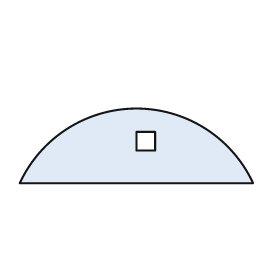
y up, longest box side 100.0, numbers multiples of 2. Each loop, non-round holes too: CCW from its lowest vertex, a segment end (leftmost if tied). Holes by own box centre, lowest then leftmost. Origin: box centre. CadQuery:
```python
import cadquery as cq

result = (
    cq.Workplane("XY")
    .moveTo(-50.0, -16.0)
    .lineTo(50.0, -16.0)
    .threePointArc((0.0, 16.0), (-50.0, -16.0))
    .close()
    .moveTo(0.0, -2.0)
    .lineTo(8.0, -2.0)
    .lineTo(8.0, 6.0)
    .lineTo(0.0, 6.0)
    .close()
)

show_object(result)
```